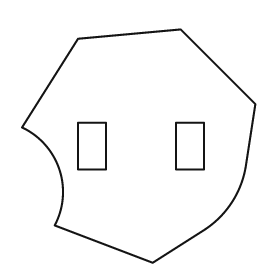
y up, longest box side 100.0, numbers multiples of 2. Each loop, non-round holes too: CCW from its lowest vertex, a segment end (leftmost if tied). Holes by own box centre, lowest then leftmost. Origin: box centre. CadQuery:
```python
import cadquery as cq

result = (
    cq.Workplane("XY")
    .moveTo(6.0, -50.0)
    .lineTo(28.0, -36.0)
    .threePointArc((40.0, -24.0), (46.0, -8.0))
    .lineTo(50.0, 18.0)
    .lineTo(18.0, 50.0)
    .lineTo(-26.0, 46.0)
    .lineTo(-50.0, 8.0)
    .threePointArc((-34.0, -10.0), (-36.0, -34.0))
    .close()
    .moveTo(-26.0, -10.0)
    .lineTo(-14.0, -10.0)
    .lineTo(-14.0, 10.0)
    .lineTo(-26.0, 10.0)
    .close()
    .moveTo(16.0, -10.0)
    .lineTo(28.0, -10.0)
    .lineTo(28.0, 10.0)
    .lineTo(16.0, 10.0)
    .close()
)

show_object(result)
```